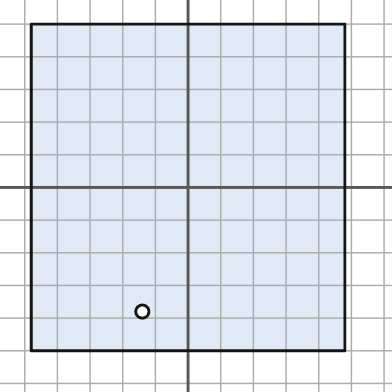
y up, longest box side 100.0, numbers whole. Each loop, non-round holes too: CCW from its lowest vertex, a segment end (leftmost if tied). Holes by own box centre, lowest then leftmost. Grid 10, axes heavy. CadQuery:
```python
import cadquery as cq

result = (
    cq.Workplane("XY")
    .moveTo(-48.0, -50.0)
    .lineTo(48.0, -50.0)
    .lineTo(48.0, 50.0)
    .lineTo(-48.0, 50.0)
    .close()
    .moveTo(-14.0, -38.0)
    .circle(2.0)
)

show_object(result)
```